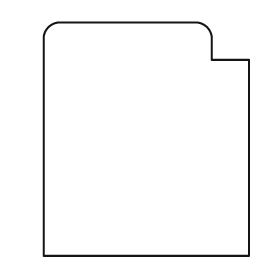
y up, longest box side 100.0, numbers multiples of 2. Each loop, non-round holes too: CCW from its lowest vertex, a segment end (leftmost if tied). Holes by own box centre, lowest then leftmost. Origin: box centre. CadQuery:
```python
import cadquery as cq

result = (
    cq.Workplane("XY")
    .moveTo(-44.0, -50.0)
    .lineTo(44.0, -50.0)
    .lineTo(44.0, 34.0)
    .lineTo(28.0, 34.0)
    .lineTo(28.0, 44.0)
    .threePointArc((26.0, 48.0), (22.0, 50.0))
    .lineTo(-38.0, 50.0)
    .threePointArc((-42.0, 48.0), (-44.0, 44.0))
    .close()
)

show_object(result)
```